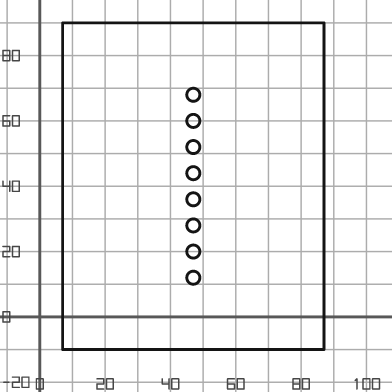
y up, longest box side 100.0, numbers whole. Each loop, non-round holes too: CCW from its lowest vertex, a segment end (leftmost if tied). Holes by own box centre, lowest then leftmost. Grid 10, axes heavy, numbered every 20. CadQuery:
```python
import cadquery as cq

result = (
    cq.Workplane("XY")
    .moveTo(7.0, -10.0)
    .lineTo(87.0, -10.0)
    .lineTo(87.0, 90.0)
    .lineTo(7.0, 90.0)
    .close()
    .moveTo(47.0, 12.0)
    .circle(2.0)
    .moveTo(47.0, 20.0)
    .circle(2.0)
    .moveTo(47.0, 28.0)
    .circle(2.0)
    .moveTo(47.0, 36.0)
    .circle(2.0)
    .moveTo(47.0, 44.0)
    .circle(2.0)
    .moveTo(47.0, 52.0)
    .circle(2.0)
    .moveTo(47.0, 60.0)
    .circle(2.0)
    .moveTo(47.0, 68.0)
    .circle(2.0)
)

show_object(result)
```